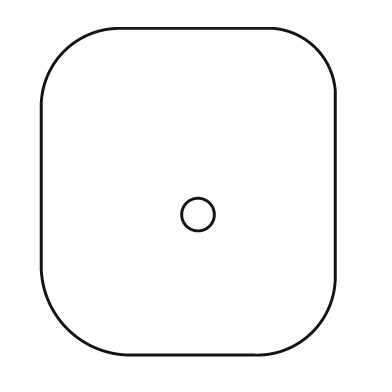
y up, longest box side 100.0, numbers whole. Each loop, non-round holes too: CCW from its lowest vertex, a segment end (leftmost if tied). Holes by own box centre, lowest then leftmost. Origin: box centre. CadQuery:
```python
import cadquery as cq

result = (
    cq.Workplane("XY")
    .moveTo(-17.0, -50.0)
    .lineTo(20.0, -50.0)
    .threePointArc((38.0, -43.0), (45.0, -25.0))
    .lineTo(45.0, 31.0)
    .threePointArc((39.0, 44.0), (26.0, 50.0))
    .lineTo(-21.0, 50.0)
    .threePointArc((-38.0, 43.0), (-45.0, 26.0))
    .lineTo(-45.0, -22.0)
    .threePointArc((-37.0, -42.0), (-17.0, -50.0))
    .close()
    .moveTo(3.0, -7.0)
    .circle(5.0)
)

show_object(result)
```